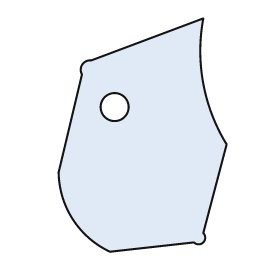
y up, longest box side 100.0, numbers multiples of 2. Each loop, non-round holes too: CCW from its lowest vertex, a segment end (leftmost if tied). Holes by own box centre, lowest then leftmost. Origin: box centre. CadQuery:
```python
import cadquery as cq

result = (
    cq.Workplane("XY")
    .moveTo(-14.0, -50.0)
    .lineTo(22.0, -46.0)
    .threePointArc((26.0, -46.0), (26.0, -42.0))
    .lineTo(36.0, -4.0)
    .threePointArc((26.0, 22.0), (26.0, 50.0))
    .lineTo(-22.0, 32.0)
    .threePointArc((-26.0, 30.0), (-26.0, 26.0))
    .lineTo(-36.0, -16.0)
    .threePointArc((-30.0, -36.0), (-14.0, -50.0))
    .close()
    .moveTo(-12.0, 12.0)
    .circle(6.0)
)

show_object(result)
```